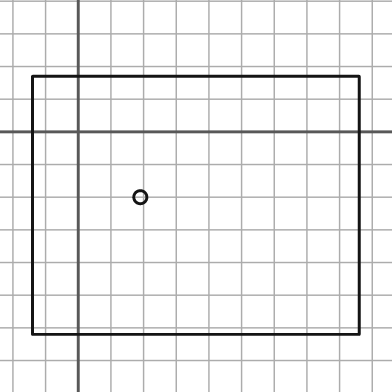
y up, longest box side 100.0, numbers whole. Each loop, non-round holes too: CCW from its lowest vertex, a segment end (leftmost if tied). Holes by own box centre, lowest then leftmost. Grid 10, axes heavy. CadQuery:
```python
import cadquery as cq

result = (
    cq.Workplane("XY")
    .moveTo(-14.0, -62.0)
    .lineTo(86.0, -62.0)
    .lineTo(86.0, 17.0)
    .lineTo(-14.0, 17.0)
    .close()
    .moveTo(19.0, -20.0)
    .circle(2.0)
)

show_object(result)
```